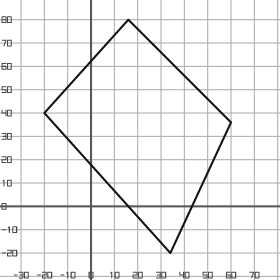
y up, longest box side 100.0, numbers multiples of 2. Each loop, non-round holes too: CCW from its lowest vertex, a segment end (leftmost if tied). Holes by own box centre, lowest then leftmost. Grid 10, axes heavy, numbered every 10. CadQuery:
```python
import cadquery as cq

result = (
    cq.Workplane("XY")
    .moveTo(34.0, -20.0)
    .lineTo(60.0, 36.0)
    .lineTo(16.0, 80.0)
    .lineTo(-20.0, 40.0)
    .close()
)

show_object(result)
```